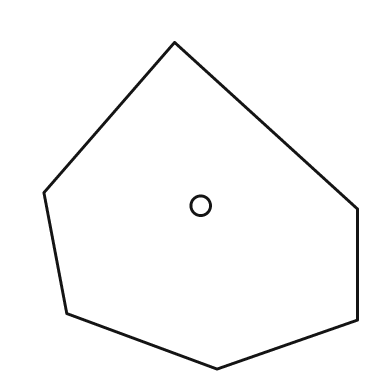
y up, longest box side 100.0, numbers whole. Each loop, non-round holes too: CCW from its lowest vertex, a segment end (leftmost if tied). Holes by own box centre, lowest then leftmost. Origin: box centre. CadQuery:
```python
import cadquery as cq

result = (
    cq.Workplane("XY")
    .moveTo(5.0, -50.0)
    .lineTo(48.0, -35.0)
    .lineTo(48.0, -1.0)
    .lineTo(-8.0, 50.0)
    .lineTo(-48.0, 4.0)
    .lineTo(-41.0, -33.0)
    .close()
    .moveTo(0.0, 0.0)
    .circle(3.0)
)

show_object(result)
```